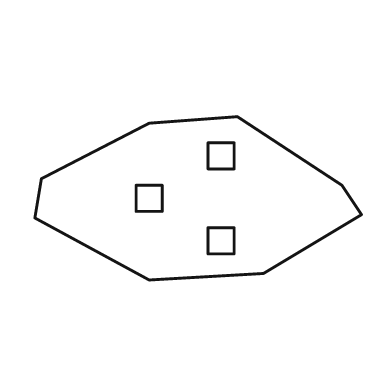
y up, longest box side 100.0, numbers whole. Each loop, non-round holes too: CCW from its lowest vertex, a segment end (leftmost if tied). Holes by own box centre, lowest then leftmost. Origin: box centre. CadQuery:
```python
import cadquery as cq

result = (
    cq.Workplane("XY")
    .moveTo(-15.0, -25.0)
    .lineTo(20.0, -23.0)
    .lineTo(50.0, -5.0)
    .lineTo(44.0, 4.0)
    .lineTo(12.0, 25.0)
    .lineTo(-15.0, 23.0)
    .lineTo(-48.0, 6.0)
    .lineTo(-50.0, -6.0)
    .close()
    .moveTo(3.0, -17.0)
    .lineTo(11.0, -17.0)
    .lineTo(11.0, -9.0)
    .lineTo(3.0, -9.0)
    .close()
    .moveTo(-19.0, -4.0)
    .lineTo(-11.0, -4.0)
    .lineTo(-11.0, 4.0)
    .lineTo(-19.0, 4.0)
    .close()
    .moveTo(3.0, 9.0)
    .lineTo(11.0, 9.0)
    .lineTo(11.0, 17.0)
    .lineTo(3.0, 17.0)
    .close()
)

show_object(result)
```